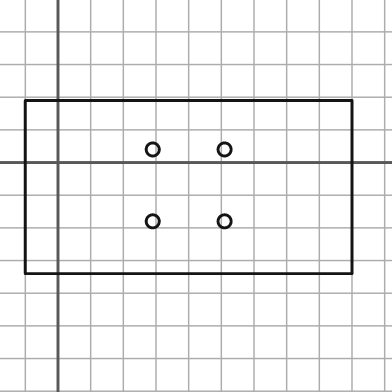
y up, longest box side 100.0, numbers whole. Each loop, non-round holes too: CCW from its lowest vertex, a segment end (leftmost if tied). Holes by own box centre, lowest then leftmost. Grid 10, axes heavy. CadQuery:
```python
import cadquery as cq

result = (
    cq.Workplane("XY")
    .moveTo(-10.0, -34.0)
    .lineTo(90.0, -34.0)
    .lineTo(90.0, 19.0)
    .lineTo(-10.0, 19.0)
    .close()
    .moveTo(29.0, -18.0)
    .circle(2.0)
    .moveTo(51.0, -18.0)
    .circle(2.0)
    .moveTo(29.0, 4.0)
    .circle(2.0)
    .moveTo(51.0, 4.0)
    .circle(2.0)
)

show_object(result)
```